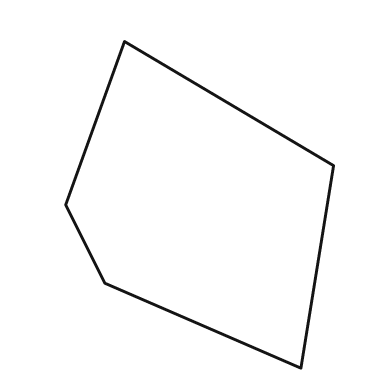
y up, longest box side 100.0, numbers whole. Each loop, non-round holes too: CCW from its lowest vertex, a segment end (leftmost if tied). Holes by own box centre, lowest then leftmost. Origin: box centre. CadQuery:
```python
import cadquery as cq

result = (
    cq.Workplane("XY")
    .moveTo(31.0, -50.0)
    .lineTo(41.0, 12.0)
    .lineTo(-23.0, 50.0)
    .lineTo(-41.0, 0.0)
    .lineTo(-29.0, -24.0)
    .close()
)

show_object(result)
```